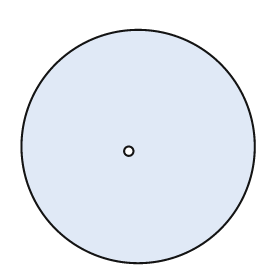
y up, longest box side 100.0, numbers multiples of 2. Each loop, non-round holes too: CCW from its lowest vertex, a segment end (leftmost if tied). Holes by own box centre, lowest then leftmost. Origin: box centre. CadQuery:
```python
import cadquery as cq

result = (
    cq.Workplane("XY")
    .moveTo(0.0, 0.0)
    .circle(50.0)
    .moveTo(-4.0, -2.0)
    .circle(2.0)
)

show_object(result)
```